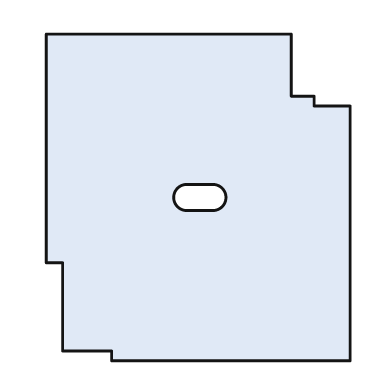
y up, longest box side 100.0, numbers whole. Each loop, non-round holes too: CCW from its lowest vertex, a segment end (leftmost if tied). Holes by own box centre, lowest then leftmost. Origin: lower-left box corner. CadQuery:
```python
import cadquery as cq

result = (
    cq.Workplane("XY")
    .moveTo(20.0, 0.0)
    .lineTo(93.0, 0.0)
    .lineTo(93.0, 78.0)
    .lineTo(82.0, 78.0)
    .lineTo(82.0, 81.0)
    .lineTo(75.0, 81.0)
    .lineTo(75.0, 100.0)
    .lineTo(0.0, 100.0)
    .lineTo(0.0, 30.0)
    .lineTo(5.0, 30.0)
    .lineTo(5.0, 3.0)
    .lineTo(20.0, 3.0)
    .close()
    .moveTo(43.0, 46.0)
    .lineTo(51.0, 46.0)
    .threePointArc((55.0, 50.0), (51.0, 54.0))
    .lineTo(43.0, 54.0)
    .threePointArc((39.0, 50.0), (43.0, 46.0))
    .close()
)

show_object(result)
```